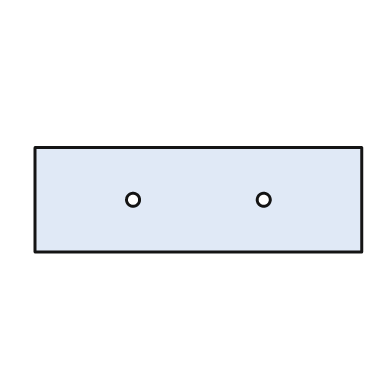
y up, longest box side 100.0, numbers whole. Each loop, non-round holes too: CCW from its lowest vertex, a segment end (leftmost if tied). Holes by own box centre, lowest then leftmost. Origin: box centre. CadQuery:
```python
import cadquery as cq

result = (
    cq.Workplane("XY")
    .moveTo(-50.0, -16.0)
    .lineTo(50.0, -16.0)
    .lineTo(50.0, 16.0)
    .lineTo(-50.0, 16.0)
    .close()
    .moveTo(-20.0, 0.0)
    .circle(2.0)
    .moveTo(20.0, 0.0)
    .circle(2.0)
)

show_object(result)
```